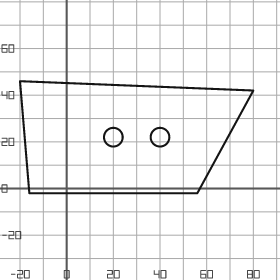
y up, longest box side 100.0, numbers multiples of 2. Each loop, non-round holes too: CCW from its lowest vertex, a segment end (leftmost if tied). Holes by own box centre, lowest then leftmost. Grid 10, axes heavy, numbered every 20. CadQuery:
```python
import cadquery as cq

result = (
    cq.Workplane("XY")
    .moveTo(-16.0, -2.0)
    .lineTo(56.0, -2.0)
    .lineTo(80.0, 42.0)
    .lineTo(-20.0, 46.0)
    .close()
    .moveTo(20.0, 22.0)
    .circle(4.0)
    .moveTo(40.0, 22.0)
    .circle(4.0)
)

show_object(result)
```